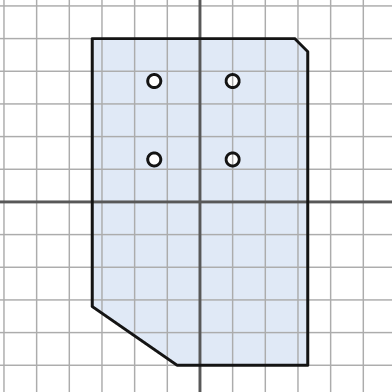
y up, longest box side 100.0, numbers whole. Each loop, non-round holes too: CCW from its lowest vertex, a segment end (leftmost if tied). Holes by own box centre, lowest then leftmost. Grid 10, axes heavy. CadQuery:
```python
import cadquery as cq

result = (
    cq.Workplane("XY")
    .moveTo(-7.0, -50.0)
    .lineTo(33.0, -50.0)
    .lineTo(33.0, 46.0)
    .lineTo(29.0, 50.0)
    .lineTo(-33.0, 50.0)
    .lineTo(-33.0, -32.0)
    .close()
    .moveTo(-14.0, 13.0)
    .circle(2.0)
    .moveTo(10.0, 13.0)
    .circle(2.0)
    .moveTo(-14.0, 37.0)
    .circle(2.0)
    .moveTo(10.0, 37.0)
    .circle(2.0)
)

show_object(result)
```